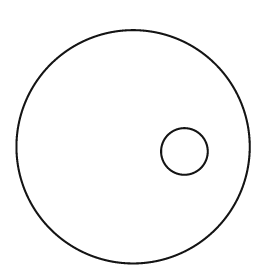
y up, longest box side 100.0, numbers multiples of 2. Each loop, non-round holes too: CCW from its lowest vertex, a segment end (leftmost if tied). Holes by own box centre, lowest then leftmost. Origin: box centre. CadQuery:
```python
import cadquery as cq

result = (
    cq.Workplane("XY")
    .moveTo(0.0, 0.0)
    .circle(50.0)
    .moveTo(22.0, -2.0)
    .circle(10.0)
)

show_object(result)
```